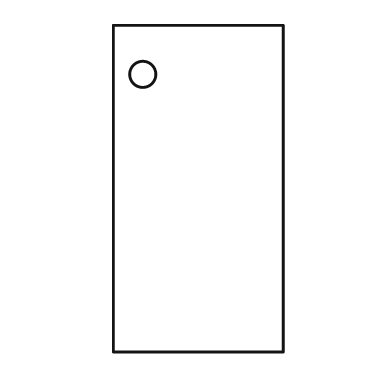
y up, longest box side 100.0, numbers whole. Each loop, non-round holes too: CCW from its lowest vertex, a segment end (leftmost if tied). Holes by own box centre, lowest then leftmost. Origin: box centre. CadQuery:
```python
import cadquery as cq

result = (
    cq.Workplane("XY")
    .moveTo(-26.0, -50.0)
    .lineTo(26.0, -50.0)
    .lineTo(26.0, 50.0)
    .lineTo(-26.0, 50.0)
    .close()
    .moveTo(-17.0, 35.0)
    .circle(4.0)
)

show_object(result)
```